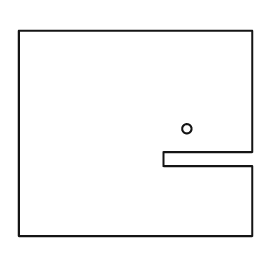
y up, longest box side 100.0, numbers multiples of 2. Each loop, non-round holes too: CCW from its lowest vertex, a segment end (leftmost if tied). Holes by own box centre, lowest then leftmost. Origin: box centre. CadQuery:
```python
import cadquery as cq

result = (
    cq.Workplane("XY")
    .moveTo(-50.0, -44.0)
    .lineTo(50.0, -44.0)
    .lineTo(50.0, -14.0)
    .lineTo(12.0, -14.0)
    .lineTo(12.0, -8.0)
    .lineTo(50.0, -8.0)
    .lineTo(50.0, 44.0)
    .lineTo(-50.0, 44.0)
    .close()
    .moveTo(22.0, 2.0)
    .circle(2.0)
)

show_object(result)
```